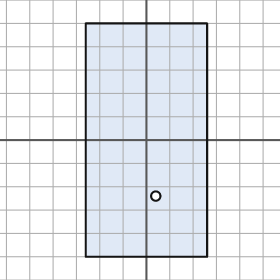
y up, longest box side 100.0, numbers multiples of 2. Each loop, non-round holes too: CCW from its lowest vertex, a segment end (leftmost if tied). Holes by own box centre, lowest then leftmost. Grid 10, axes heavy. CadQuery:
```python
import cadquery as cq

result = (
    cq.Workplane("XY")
    .moveTo(-26.0, -50.0)
    .lineTo(26.0, -50.0)
    .lineTo(26.0, 50.0)
    .lineTo(-26.0, 50.0)
    .close()
    .moveTo(4.0, -24.0)
    .circle(2.0)
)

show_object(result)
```